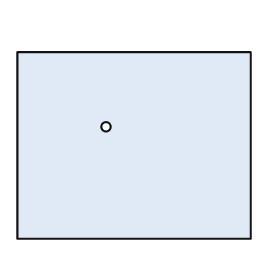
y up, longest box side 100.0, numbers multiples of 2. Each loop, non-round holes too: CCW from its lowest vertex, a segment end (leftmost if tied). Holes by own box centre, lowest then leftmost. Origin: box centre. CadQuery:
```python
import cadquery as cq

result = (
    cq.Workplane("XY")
    .moveTo(-50.0, -40.0)
    .lineTo(50.0, -40.0)
    .lineTo(50.0, 40.0)
    .lineTo(-50.0, 40.0)
    .close()
    .moveTo(-12.0, 8.0)
    .circle(2.0)
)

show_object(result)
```